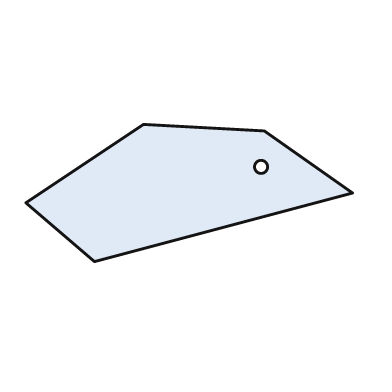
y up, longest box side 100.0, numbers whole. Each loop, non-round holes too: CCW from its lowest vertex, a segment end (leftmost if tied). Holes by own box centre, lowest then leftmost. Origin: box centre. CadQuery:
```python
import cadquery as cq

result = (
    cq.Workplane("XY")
    .moveTo(-29.0, -21.0)
    .lineTo(50.0, 0.0)
    .lineTo(23.0, 19.0)
    .lineTo(-14.0, 21.0)
    .lineTo(-50.0, -3.0)
    .close()
    .moveTo(22.0, 8.0)
    .circle(2.0)
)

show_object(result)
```